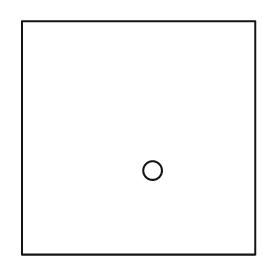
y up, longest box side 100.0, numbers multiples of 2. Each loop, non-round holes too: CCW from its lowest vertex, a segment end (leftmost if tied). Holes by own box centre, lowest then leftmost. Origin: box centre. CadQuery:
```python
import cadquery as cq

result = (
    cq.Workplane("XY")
    .moveTo(-50.0, -50.0)
    .lineTo(50.0, -50.0)
    .lineTo(50.0, 50.0)
    .lineTo(-50.0, 50.0)
    .close()
    .moveTo(6.0, -14.0)
    .circle(4.0)
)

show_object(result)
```